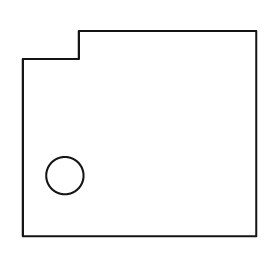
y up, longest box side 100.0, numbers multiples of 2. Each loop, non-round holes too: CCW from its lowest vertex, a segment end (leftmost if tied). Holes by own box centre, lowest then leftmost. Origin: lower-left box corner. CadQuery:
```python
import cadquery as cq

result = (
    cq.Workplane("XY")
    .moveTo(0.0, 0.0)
    .lineTo(100.0, 0.0)
    .lineTo(100.0, 88.0)
    .lineTo(24.0, 88.0)
    .lineTo(24.0, 76.0)
    .lineTo(0.0, 76.0)
    .close()
    .moveTo(18.0, 26.0)
    .circle(8.0)
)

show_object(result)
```